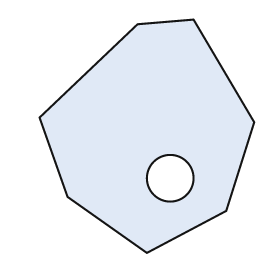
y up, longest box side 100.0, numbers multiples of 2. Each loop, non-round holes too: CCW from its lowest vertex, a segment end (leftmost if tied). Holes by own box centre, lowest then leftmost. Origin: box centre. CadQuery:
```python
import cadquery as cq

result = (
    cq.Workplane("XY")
    .moveTo(0.0, -50.0)
    .lineTo(34.0, -32.0)
    .lineTo(46.0, 6.0)
    .lineTo(20.0, 50.0)
    .lineTo(-4.0, 48.0)
    .lineTo(-46.0, 8.0)
    .lineTo(-34.0, -26.0)
    .close()
    .moveTo(10.0, -18.0)
    .circle(10.0)
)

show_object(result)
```